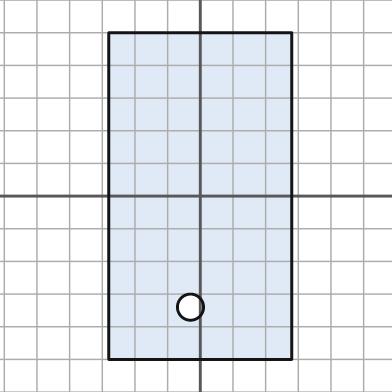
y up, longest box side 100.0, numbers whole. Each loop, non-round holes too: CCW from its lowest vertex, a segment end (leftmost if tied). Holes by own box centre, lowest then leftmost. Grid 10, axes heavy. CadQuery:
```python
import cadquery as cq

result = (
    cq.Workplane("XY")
    .moveTo(-28.0, -50.0)
    .lineTo(28.0, -50.0)
    .lineTo(28.0, 50.0)
    .lineTo(-28.0, 50.0)
    .close()
    .moveTo(-3.0, -34.0)
    .circle(4.0)
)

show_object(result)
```